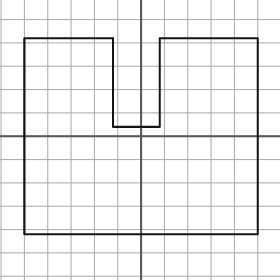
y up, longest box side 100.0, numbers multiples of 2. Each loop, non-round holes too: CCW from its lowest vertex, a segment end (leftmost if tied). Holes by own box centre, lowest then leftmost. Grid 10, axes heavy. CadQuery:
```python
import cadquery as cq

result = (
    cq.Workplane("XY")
    .moveTo(-50.0, -42.0)
    .lineTo(50.0, -42.0)
    .lineTo(50.0, 42.0)
    .lineTo(8.0, 42.0)
    .lineTo(8.0, 4.0)
    .lineTo(-12.0, 4.0)
    .lineTo(-12.0, 42.0)
    .lineTo(-50.0, 42.0)
    .close()
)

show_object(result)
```